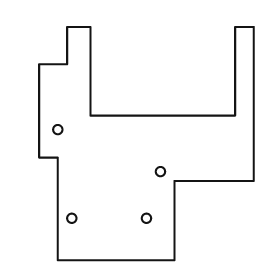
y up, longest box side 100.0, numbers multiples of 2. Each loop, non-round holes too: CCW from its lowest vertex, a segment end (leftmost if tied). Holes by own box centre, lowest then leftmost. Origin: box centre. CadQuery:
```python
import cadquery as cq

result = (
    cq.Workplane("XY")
    .moveTo(-38.0, -50.0)
    .lineTo(12.0, -50.0)
    .lineTo(12.0, -16.0)
    .lineTo(46.0, -16.0)
    .lineTo(46.0, 50.0)
    .lineTo(38.0, 50.0)
    .lineTo(38.0, 12.0)
    .lineTo(-24.0, 12.0)
    .lineTo(-24.0, 50.0)
    .lineTo(-34.0, 50.0)
    .lineTo(-34.0, 34.0)
    .lineTo(-46.0, 34.0)
    .lineTo(-46.0, -6.0)
    .lineTo(-38.0, -6.0)
    .close()
    .moveTo(-32.0, -32.0)
    .circle(2.0)
    .moveTo(0.0, -32.0)
    .circle(2.0)
    .moveTo(6.0, -12.0)
    .circle(2.0)
    .moveTo(-38.0, 6.0)
    .circle(2.0)
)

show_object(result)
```